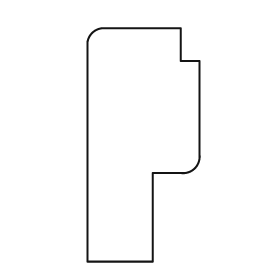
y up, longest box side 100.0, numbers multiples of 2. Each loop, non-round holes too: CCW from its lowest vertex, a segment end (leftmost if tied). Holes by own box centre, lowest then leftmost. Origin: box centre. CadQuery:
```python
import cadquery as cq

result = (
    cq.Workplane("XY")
    .moveTo(-24.0, -50.0)
    .lineTo(4.0, -50.0)
    .lineTo(4.0, -12.0)
    .lineTo(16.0, -12.0)
    .threePointArc((22.0, -10.0), (24.0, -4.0))
    .lineTo(24.0, 36.0)
    .lineTo(16.0, 36.0)
    .lineTo(16.0, 50.0)
    .lineTo(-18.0, 50.0)
    .threePointArc((-22.0, 48.0), (-24.0, 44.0))
    .close()
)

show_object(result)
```